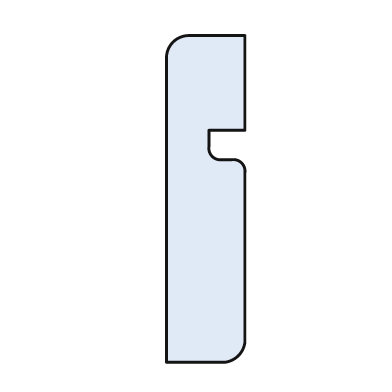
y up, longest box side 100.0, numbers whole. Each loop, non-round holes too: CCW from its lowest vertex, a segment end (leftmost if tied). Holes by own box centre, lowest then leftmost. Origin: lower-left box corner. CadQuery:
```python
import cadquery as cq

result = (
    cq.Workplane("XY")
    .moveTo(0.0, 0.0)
    .lineTo(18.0, 0.0)
    .threePointArc((22.0, 2.0), (24.0, 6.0))
    .lineTo(24.0, 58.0)
    .threePointArc((23.0, 61.0), (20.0, 62.0))
    .lineTo(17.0, 62.0)
    .threePointArc((14.0, 63.0), (13.0, 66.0))
    .lineTo(13.0, 71.0)
    .lineTo(24.0, 71.0)
    .lineTo(24.0, 100.0)
    .lineTo(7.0, 100.0)
    .threePointArc((2.0, 98.0), (0.0, 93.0))
    .close()
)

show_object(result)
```